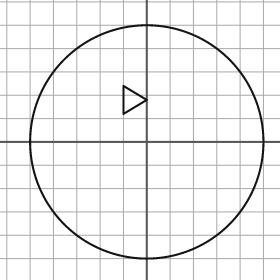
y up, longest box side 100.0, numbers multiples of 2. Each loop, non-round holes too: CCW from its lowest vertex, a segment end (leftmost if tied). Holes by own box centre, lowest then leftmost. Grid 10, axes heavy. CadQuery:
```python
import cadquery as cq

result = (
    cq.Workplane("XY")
    .moveTo(0.0, 0.0)
    .circle(50.0)
    .moveTo(-10.0, 12.0)
    .lineTo(0.0, 18.0)
    .lineTo(-10.0, 24.0)
    .close()
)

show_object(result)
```